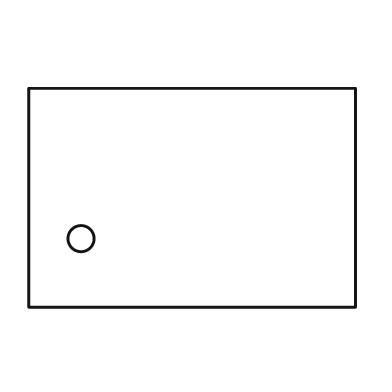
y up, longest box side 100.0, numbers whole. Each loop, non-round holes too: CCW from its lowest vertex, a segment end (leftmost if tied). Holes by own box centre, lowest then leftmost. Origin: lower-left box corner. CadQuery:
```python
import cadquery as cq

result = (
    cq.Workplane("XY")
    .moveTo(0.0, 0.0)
    .lineTo(100.0, 0.0)
    .lineTo(100.0, 67.0)
    .lineTo(0.0, 67.0)
    .close()
    .moveTo(16.0, 21.0)
    .circle(4.0)
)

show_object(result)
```